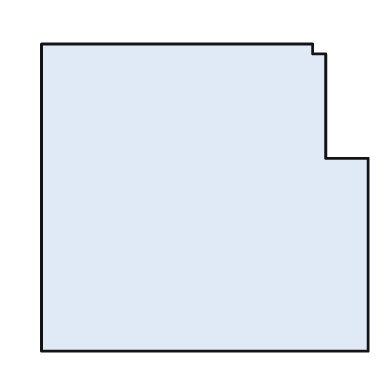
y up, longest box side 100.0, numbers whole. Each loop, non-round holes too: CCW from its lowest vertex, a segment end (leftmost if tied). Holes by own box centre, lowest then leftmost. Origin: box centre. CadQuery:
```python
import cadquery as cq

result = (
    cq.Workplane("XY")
    .moveTo(-50.0, -47.0)
    .lineTo(50.0, -47.0)
    .lineTo(50.0, 12.0)
    .lineTo(37.0, 12.0)
    .lineTo(37.0, 44.0)
    .lineTo(33.0, 44.0)
    .lineTo(33.0, 47.0)
    .lineTo(-50.0, 47.0)
    .close()
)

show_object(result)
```